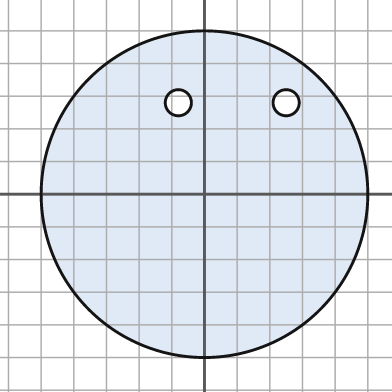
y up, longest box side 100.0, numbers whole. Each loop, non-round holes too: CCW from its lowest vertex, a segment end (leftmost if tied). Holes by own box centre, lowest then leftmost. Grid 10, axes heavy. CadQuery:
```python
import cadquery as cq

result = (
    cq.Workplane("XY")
    .moveTo(0.0, 0.0)
    .circle(50.0)
    .moveTo(-8.0, 28.0)
    .circle(4.0)
    .moveTo(25.0, 28.0)
    .circle(4.0)
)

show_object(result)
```